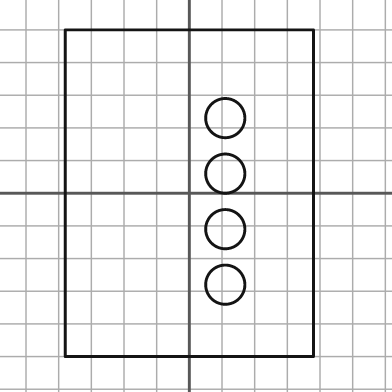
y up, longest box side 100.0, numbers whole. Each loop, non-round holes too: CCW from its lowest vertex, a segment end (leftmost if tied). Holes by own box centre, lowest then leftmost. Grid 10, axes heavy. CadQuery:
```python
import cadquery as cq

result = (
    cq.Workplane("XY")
    .moveTo(-38.0, -50.0)
    .lineTo(38.0, -50.0)
    .lineTo(38.0, 50.0)
    .lineTo(-38.0, 50.0)
    .close()
    .moveTo(11.0, -28.0)
    .circle(6.0)
    .moveTo(11.0, -11.0)
    .circle(6.0)
    .moveTo(11.0, 6.0)
    .circle(6.0)
    .moveTo(11.0, 23.0)
    .circle(6.0)
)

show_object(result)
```